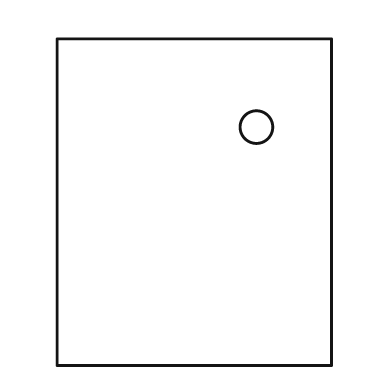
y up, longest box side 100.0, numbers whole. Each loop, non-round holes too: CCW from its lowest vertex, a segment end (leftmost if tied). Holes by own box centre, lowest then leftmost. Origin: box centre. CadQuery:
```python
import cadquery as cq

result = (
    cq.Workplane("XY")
    .moveTo(-42.0, -50.0)
    .lineTo(42.0, -50.0)
    .lineTo(42.0, 50.0)
    .lineTo(-42.0, 50.0)
    .close()
    .moveTo(19.0, 23.0)
    .circle(5.0)
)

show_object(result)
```